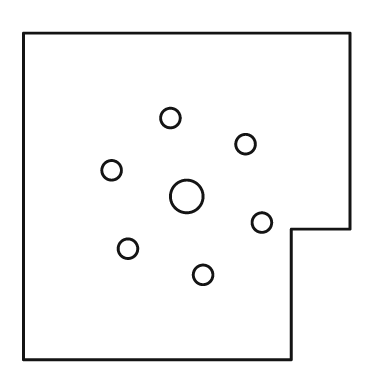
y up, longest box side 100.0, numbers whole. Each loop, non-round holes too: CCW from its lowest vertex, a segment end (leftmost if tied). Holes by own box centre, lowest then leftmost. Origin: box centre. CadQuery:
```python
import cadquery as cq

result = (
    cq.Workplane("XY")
    .moveTo(-50.0, -50.0)
    .lineTo(32.0, -50.0)
    .lineTo(32.0, -10.0)
    .lineTo(50.0, -10.0)
    .lineTo(50.0, 50.0)
    .lineTo(-50.0, 50.0)
    .close()
    .moveTo(5.0, -24.0)
    .circle(3.0)
    .moveTo(-18.0, -16.0)
    .circle(3.0)
    .moveTo(23.0, -8.0)
    .circle(3.0)
    .moveTo(0.0, 0.0)
    .circle(5.0)
    .moveTo(-23.0, 8.0)
    .circle(3.0)
    .moveTo(18.0, 16.0)
    .circle(3.0)
    .moveTo(-5.0, 24.0)
    .circle(3.0)
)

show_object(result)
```